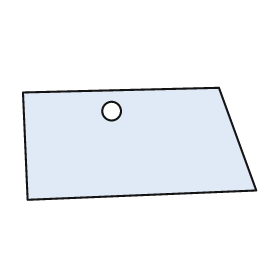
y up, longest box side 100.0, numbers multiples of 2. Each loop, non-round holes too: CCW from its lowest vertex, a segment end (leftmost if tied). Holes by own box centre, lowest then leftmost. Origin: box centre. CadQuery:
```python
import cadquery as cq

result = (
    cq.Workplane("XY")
    .moveTo(-48.0, -24.0)
    .lineTo(50.0, -20.0)
    .lineTo(34.0, 24.0)
    .lineTo(-50.0, 22.0)
    .close()
    .moveTo(-12.0, 14.0)
    .circle(4.0)
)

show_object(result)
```